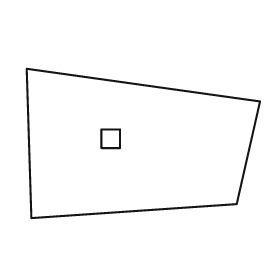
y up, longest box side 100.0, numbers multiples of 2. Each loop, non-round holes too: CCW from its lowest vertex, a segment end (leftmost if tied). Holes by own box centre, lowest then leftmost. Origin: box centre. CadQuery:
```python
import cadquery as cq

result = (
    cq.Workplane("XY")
    .moveTo(-48.0, -32.0)
    .lineTo(40.0, -26.0)
    .lineTo(50.0, 18.0)
    .lineTo(-50.0, 32.0)
    .close()
    .moveTo(-18.0, -2.0)
    .lineTo(-10.0, -2.0)
    .lineTo(-10.0, 6.0)
    .lineTo(-18.0, 6.0)
    .close()
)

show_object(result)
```